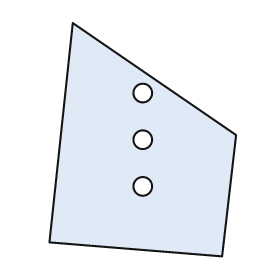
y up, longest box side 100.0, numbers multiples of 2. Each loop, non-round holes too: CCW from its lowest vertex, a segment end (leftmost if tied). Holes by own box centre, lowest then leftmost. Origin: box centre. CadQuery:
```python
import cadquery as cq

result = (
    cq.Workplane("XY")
    .moveTo(34.0, -50.0)
    .lineTo(40.0, 2.0)
    .lineTo(-30.0, 50.0)
    .lineTo(-40.0, -44.0)
    .close()
    .moveTo(0.0, -20.0)
    .circle(4.0)
    .moveTo(0.0, 0.0)
    .circle(4.0)
    .moveTo(0.0, 20.0)
    .circle(4.0)
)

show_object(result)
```